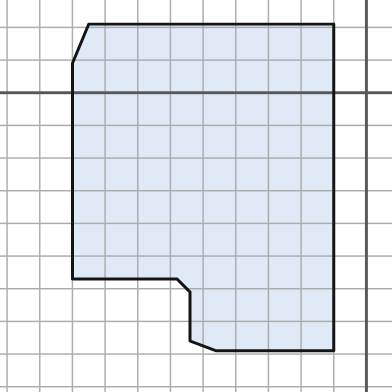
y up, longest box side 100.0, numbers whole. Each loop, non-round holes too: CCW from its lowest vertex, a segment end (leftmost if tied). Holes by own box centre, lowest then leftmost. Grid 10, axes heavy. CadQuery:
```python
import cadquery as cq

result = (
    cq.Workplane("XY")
    .moveTo(-46.0, -79.0)
    .lineTo(-10.0, -79.0)
    .lineTo(-10.0, 21.0)
    .lineTo(-85.0, 21.0)
    .lineTo(-90.0, 9.0)
    .lineTo(-90.0, -57.0)
    .lineTo(-58.0, -57.0)
    .lineTo(-54.0, -61.0)
    .lineTo(-54.0, -76.0)
    .close()
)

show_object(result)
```